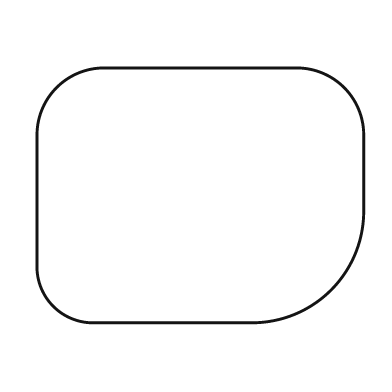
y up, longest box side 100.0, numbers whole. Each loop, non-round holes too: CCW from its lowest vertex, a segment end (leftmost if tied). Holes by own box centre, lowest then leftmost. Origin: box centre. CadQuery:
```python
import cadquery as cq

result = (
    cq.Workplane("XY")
    .moveTo(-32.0, -39.0)
    .lineTo(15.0, -39.0)
    .threePointArc((40.0, -29.0), (50.0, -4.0))
    .lineTo(50.0, 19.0)
    .threePointArc((44.0, 33.0), (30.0, 39.0))
    .lineTo(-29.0, 39.0)
    .threePointArc((-44.0, 33.0), (-50.0, 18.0))
    .lineTo(-50.0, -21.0)
    .threePointArc((-45.0, -34.0), (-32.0, -39.0))
    .close()
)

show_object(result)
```